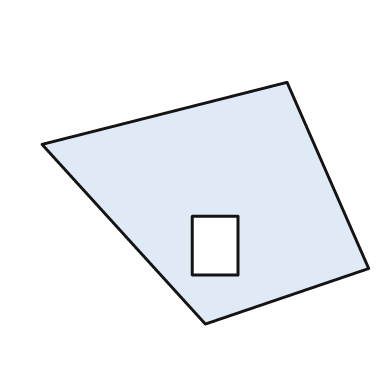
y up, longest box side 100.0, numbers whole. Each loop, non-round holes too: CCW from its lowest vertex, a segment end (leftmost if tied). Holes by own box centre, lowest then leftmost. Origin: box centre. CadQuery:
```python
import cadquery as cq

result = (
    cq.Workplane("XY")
    .moveTo(0.0, -37.0)
    .lineTo(50.0, -20.0)
    .lineTo(25.0, 37.0)
    .lineTo(-50.0, 18.0)
    .close()
    .moveTo(-4.0, -22.0)
    .lineTo(10.0, -22.0)
    .lineTo(10.0, -4.0)
    .lineTo(-4.0, -4.0)
    .close()
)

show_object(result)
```